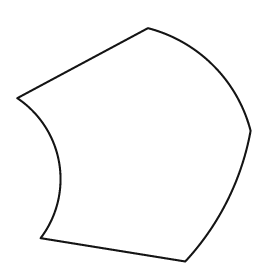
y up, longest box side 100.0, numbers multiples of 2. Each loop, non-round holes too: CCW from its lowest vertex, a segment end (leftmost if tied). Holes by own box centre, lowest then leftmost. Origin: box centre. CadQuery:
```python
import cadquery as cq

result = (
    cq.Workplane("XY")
    .moveTo(22.0, -50.0)
    .threePointArc((40.0, -24.0), (50.0, 6.0))
    .threePointArc((34.0, 34.0), (6.0, 50.0))
    .lineTo(-50.0, 20.0)
    .threePointArc((-32.0, -8.0), (-40.0, -40.0))
    .close()
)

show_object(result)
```